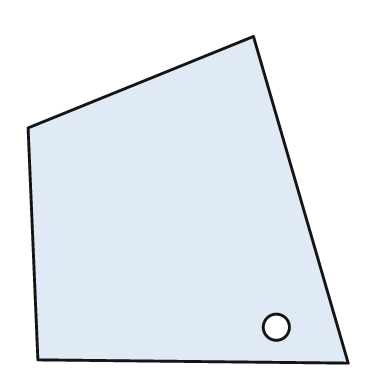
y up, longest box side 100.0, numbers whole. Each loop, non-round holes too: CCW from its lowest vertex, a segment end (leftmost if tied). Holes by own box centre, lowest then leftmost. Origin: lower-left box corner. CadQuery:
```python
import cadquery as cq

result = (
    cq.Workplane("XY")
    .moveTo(98.0, 0.0)
    .lineTo(69.0, 100.0)
    .lineTo(0.0, 72.0)
    .lineTo(3.0, 1.0)
    .close()
    .moveTo(76.0, 11.0)
    .circle(4.0)
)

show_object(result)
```